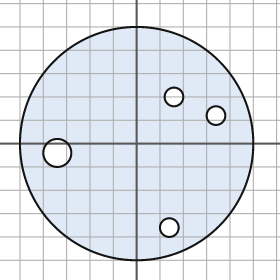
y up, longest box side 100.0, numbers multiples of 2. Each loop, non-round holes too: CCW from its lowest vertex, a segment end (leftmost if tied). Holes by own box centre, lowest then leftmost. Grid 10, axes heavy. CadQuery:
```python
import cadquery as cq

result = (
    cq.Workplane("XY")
    .moveTo(0.0, 0.0)
    .circle(50.0)
    .moveTo(14.0, -36.0)
    .circle(4.0)
    .moveTo(-34.0, -4.0)
    .circle(6.0)
    .moveTo(34.0, 12.0)
    .circle(4.0)
    .moveTo(16.0, 20.0)
    .circle(4.0)
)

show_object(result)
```